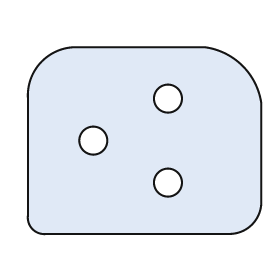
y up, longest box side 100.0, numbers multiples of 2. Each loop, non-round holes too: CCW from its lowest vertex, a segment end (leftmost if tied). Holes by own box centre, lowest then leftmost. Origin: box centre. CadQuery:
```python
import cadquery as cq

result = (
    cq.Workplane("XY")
    .moveTo(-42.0, -40.0)
    .lineTo(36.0, -40.0)
    .threePointArc((46.0, -36.0), (50.0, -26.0))
    .lineTo(50.0, 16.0)
    .threePointArc((42.0, 32.0), (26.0, 40.0))
    .lineTo(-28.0, 40.0)
    .threePointArc((-44.0, 34.0), (-50.0, 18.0))
    .lineTo(-50.0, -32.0)
    .threePointArc((-48.0, -38.0), (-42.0, -40.0))
    .close()
    .moveTo(10.0, -18.0)
    .circle(6.0)
    .moveTo(-22.0, 0.0)
    .circle(6.0)
    .moveTo(10.0, 18.0)
    .circle(6.0)
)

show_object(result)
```